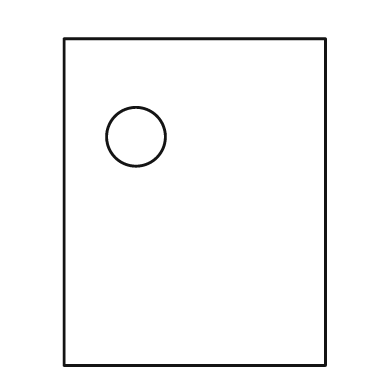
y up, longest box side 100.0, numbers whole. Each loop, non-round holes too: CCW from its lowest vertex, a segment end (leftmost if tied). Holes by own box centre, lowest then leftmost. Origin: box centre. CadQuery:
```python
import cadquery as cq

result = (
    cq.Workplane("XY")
    .moveTo(-40.0, -50.0)
    .lineTo(40.0, -50.0)
    .lineTo(40.0, 50.0)
    .lineTo(-40.0, 50.0)
    .close()
    .moveTo(-18.0, 20.0)
    .circle(9.0)
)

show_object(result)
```